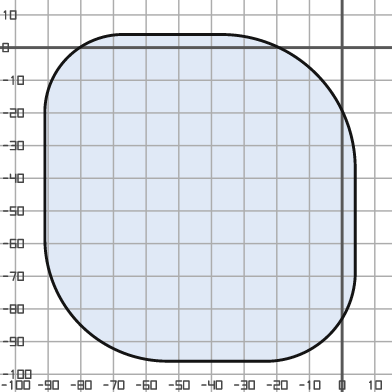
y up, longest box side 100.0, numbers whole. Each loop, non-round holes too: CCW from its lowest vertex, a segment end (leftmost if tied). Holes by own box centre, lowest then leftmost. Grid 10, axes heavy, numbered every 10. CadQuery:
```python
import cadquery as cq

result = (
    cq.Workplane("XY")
    .moveTo(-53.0, -96.0)
    .lineTo(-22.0, -96.0)
    .threePointArc((-4.0, -88.0), (4.0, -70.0))
    .lineTo(4.0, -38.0)
    .threePointArc((-8.0, -8.0), (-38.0, 4.0))
    .lineTo(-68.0, 4.0)
    .threePointArc((-84.0, -3.0), (-91.0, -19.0))
    .lineTo(-91.0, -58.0)
    .threePointArc((-80.0, -85.0), (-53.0, -96.0))
    .close()
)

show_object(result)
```